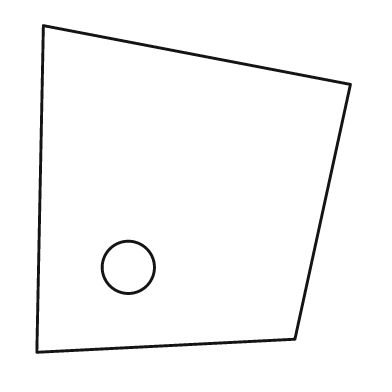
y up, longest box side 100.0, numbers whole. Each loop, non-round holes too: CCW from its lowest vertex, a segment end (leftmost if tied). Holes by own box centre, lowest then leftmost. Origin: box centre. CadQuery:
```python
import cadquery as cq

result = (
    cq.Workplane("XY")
    .moveTo(-48.0, -50.0)
    .lineTo(31.0, -46.0)
    .lineTo(48.0, 32.0)
    .lineTo(-46.0, 50.0)
    .close()
    .moveTo(-20.0, -24.0)
    .circle(8.0)
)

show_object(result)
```